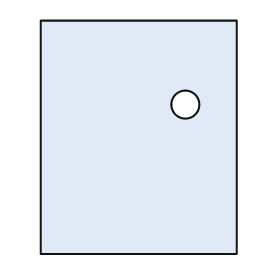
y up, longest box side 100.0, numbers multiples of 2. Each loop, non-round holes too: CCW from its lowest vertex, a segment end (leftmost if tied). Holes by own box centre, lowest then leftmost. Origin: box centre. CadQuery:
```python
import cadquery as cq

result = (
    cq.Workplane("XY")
    .moveTo(-42.0, -50.0)
    .lineTo(42.0, -50.0)
    .lineTo(42.0, 50.0)
    .lineTo(-42.0, 50.0)
    .close()
    .moveTo(20.0, 14.0)
    .circle(6.0)
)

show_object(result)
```